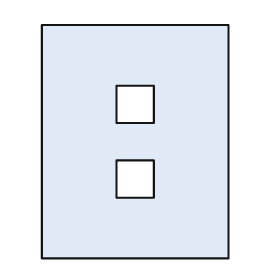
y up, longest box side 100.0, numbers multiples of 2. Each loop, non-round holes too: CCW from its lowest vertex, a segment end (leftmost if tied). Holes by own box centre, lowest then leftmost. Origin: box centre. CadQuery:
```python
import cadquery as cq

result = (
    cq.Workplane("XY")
    .moveTo(-40.0, -50.0)
    .lineTo(40.0, -50.0)
    .lineTo(40.0, 50.0)
    .lineTo(-40.0, 50.0)
    .close()
    .moveTo(-8.0, -24.0)
    .lineTo(8.0, -24.0)
    .lineTo(8.0, -8.0)
    .lineTo(-8.0, -8.0)
    .close()
    .moveTo(-8.0, 8.0)
    .lineTo(8.0, 8.0)
    .lineTo(8.0, 24.0)
    .lineTo(-8.0, 24.0)
    .close()
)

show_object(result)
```